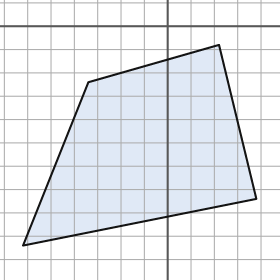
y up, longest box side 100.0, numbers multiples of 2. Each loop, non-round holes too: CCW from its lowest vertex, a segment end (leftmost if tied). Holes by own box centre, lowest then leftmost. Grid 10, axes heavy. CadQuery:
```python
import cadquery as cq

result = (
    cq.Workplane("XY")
    .moveTo(-62.0, -94.0)
    .lineTo(38.0, -74.0)
    .lineTo(22.0, -8.0)
    .lineTo(-34.0, -24.0)
    .close()
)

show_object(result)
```